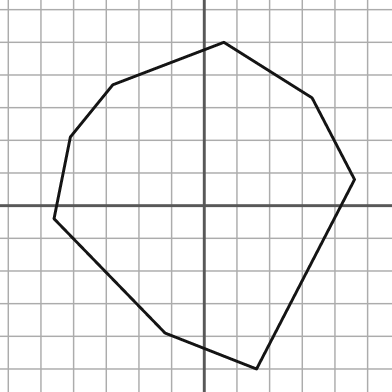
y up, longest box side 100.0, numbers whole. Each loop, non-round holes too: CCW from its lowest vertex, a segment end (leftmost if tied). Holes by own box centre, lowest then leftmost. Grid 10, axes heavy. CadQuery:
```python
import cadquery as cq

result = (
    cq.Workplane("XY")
    .moveTo(16.0, -50.0)
    .lineTo(46.0, 8.0)
    .lineTo(33.0, 33.0)
    .lineTo(6.0, 50.0)
    .lineTo(-28.0, 37.0)
    .lineTo(-41.0, 21.0)
    .lineTo(-46.0, -4.0)
    .lineTo(-12.0, -39.0)
    .close()
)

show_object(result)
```